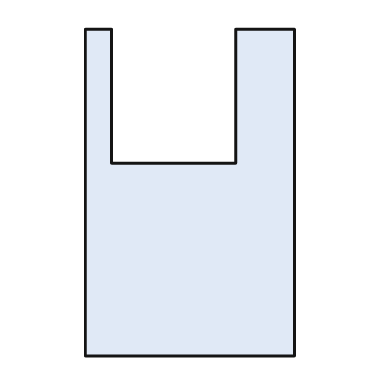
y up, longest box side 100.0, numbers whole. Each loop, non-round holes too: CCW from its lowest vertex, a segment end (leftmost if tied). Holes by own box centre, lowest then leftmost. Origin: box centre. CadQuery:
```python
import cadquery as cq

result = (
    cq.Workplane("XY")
    .moveTo(-32.0, -50.0)
    .lineTo(32.0, -50.0)
    .lineTo(32.0, 50.0)
    .lineTo(14.0, 50.0)
    .lineTo(14.0, 9.0)
    .lineTo(-24.0, 9.0)
    .lineTo(-24.0, 50.0)
    .lineTo(-32.0, 50.0)
    .close()
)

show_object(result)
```